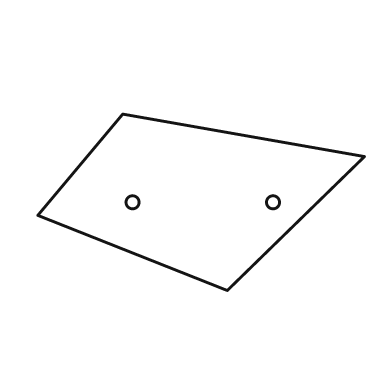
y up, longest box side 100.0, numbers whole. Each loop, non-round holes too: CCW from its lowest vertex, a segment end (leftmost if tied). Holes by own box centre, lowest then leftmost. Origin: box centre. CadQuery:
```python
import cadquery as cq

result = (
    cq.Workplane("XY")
    .moveTo(8.0, -27.0)
    .lineTo(50.0, 14.0)
    .lineTo(-24.0, 27.0)
    .lineTo(-50.0, -4.0)
    .close()
    .moveTo(-21.0, 0.0)
    .circle(2.0)
    .moveTo(22.0, 0.0)
    .circle(2.0)
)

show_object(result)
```